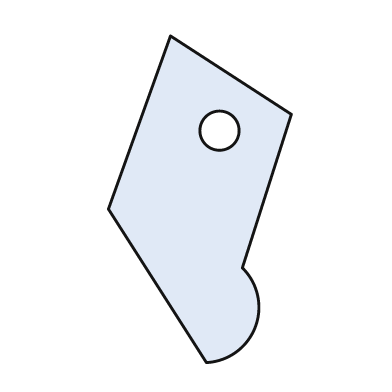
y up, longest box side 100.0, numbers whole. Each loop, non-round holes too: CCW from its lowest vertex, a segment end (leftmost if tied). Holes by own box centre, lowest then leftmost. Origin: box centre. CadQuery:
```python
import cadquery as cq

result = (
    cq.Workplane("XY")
    .moveTo(2.0, -50.0)
    .threePointArc((17.0, -39.0), (13.0, -21.0))
    .lineTo(28.0, 26.0)
    .lineTo(-9.0, 50.0)
    .lineTo(-28.0, -3.0)
    .close()
    .moveTo(6.0, 21.0)
    .circle(6.0)
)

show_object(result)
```